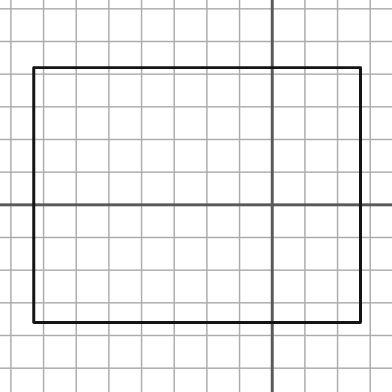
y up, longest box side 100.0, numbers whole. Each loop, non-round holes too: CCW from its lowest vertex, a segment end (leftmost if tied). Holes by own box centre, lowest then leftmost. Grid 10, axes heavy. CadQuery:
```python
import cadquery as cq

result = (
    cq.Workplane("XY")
    .moveTo(-73.0, -36.0)
    .lineTo(27.0, -36.0)
    .lineTo(27.0, 42.0)
    .lineTo(-73.0, 42.0)
    .close()
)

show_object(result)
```